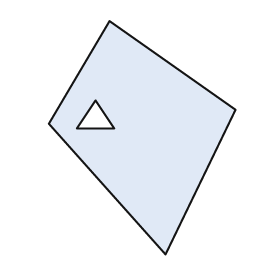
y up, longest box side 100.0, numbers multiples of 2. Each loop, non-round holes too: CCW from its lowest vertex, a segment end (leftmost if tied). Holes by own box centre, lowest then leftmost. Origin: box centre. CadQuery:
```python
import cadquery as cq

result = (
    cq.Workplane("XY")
    .moveTo(10.0, -50.0)
    .lineTo(40.0, 12.0)
    .lineTo(-14.0, 50.0)
    .lineTo(-40.0, 6.0)
    .close()
    .moveTo(-28.0, 4.0)
    .lineTo(-12.0, 4.0)
    .lineTo(-20.0, 16.0)
    .close()
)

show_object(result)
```